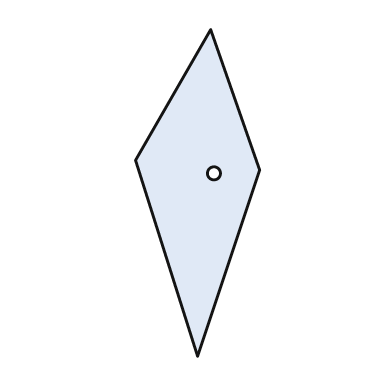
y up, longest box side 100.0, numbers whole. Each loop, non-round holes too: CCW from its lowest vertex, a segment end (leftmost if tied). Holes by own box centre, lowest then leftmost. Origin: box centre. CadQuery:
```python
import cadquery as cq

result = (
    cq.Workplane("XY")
    .moveTo(0.0, -50.0)
    .lineTo(19.0, 7.0)
    .lineTo(4.0, 50.0)
    .lineTo(-19.0, 10.0)
    .close()
    .moveTo(5.0, 6.0)
    .circle(2.0)
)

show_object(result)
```